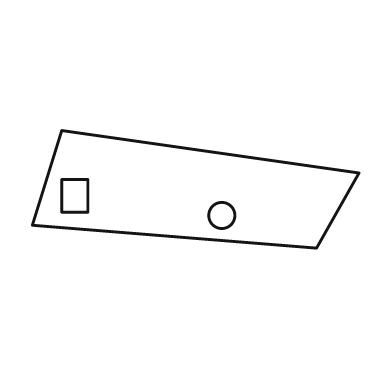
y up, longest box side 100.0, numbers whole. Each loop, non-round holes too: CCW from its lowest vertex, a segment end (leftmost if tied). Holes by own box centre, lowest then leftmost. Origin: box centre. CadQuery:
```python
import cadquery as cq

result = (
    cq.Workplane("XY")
    .moveTo(37.0, -18.0)
    .lineTo(50.0, 5.0)
    .lineTo(-41.0, 18.0)
    .lineTo(-50.0, -11.0)
    .close()
    .moveTo(8.0, -8.0)
    .circle(4.0)
    .moveTo(-41.0, -7.0)
    .lineTo(-33.0, -7.0)
    .lineTo(-33.0, 3.0)
    .lineTo(-41.0, 3.0)
    .close()
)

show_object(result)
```